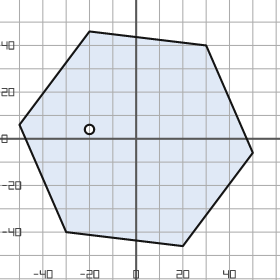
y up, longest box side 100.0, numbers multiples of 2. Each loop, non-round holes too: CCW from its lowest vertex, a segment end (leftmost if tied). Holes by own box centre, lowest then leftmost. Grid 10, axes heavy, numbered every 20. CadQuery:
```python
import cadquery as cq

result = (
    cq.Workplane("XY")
    .moveTo(20.0, -46.0)
    .lineTo(50.0, -6.0)
    .lineTo(30.0, 40.0)
    .lineTo(-20.0, 46.0)
    .lineTo(-50.0, 6.0)
    .lineTo(-30.0, -40.0)
    .close()
    .moveTo(-20.0, 4.0)
    .circle(2.0)
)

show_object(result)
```